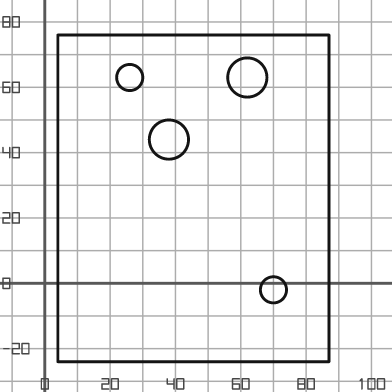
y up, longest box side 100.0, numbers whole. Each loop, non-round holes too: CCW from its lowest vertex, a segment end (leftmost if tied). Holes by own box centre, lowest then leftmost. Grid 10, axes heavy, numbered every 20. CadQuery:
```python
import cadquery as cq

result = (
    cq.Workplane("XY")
    .moveTo(4.0, -24.0)
    .lineTo(87.0, -24.0)
    .lineTo(87.0, 76.0)
    .lineTo(4.0, 76.0)
    .close()
    .moveTo(70.0, -2.0)
    .circle(4.0)
    .moveTo(38.0, 44.0)
    .circle(6.0)
    .moveTo(26.0, 63.0)
    .circle(4.0)
    .moveTo(62.0, 63.0)
    .circle(6.0)
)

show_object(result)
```